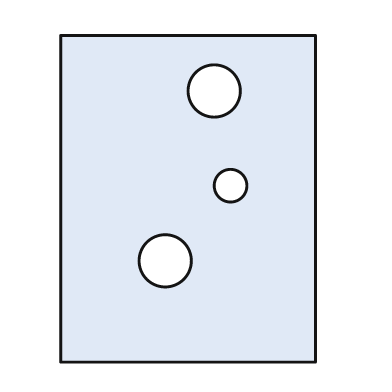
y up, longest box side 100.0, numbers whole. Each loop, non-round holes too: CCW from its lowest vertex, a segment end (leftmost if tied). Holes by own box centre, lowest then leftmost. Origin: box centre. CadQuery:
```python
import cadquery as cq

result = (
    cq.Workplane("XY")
    .moveTo(-39.0, -50.0)
    .lineTo(39.0, -50.0)
    .lineTo(39.0, 50.0)
    .lineTo(-39.0, 50.0)
    .close()
    .moveTo(-7.0, -19.0)
    .circle(8.0)
    .moveTo(13.0, 4.0)
    .circle(5.0)
    .moveTo(8.0, 33.0)
    .circle(8.0)
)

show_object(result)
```